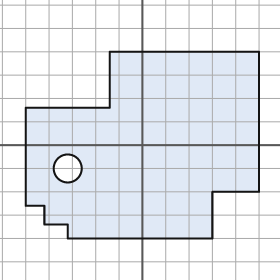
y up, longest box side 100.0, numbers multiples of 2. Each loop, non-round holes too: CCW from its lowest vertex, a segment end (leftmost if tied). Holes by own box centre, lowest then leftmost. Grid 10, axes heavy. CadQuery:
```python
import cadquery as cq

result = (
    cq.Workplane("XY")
    .moveTo(-32.0, -40.0)
    .lineTo(30.0, -40.0)
    .lineTo(30.0, -20.0)
    .lineTo(50.0, -20.0)
    .lineTo(50.0, 40.0)
    .lineTo(-14.0, 40.0)
    .lineTo(-14.0, 16.0)
    .lineTo(-50.0, 16.0)
    .lineTo(-50.0, -26.0)
    .lineTo(-42.0, -26.0)
    .lineTo(-42.0, -34.0)
    .lineTo(-32.0, -34.0)
    .close()
    .moveTo(-32.0, -10.0)
    .circle(6.0)
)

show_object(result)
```